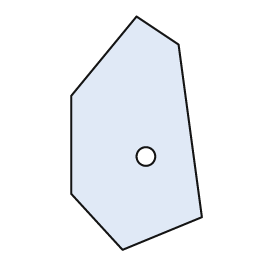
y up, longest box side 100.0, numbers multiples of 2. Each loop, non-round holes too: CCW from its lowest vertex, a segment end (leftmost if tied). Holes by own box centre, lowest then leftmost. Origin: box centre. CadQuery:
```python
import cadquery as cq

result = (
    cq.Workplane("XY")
    .moveTo(-6.0, -50.0)
    .lineTo(28.0, -36.0)
    .lineTo(18.0, 38.0)
    .lineTo(0.0, 50.0)
    .lineTo(-28.0, 16.0)
    .lineTo(-28.0, -26.0)
    .close()
    .moveTo(4.0, -10.0)
    .circle(4.0)
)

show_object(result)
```